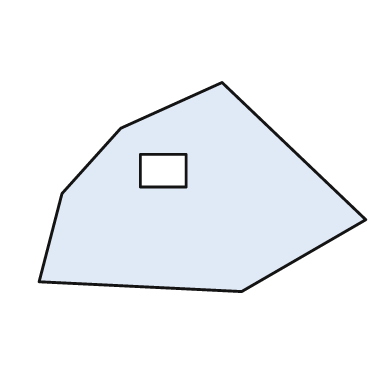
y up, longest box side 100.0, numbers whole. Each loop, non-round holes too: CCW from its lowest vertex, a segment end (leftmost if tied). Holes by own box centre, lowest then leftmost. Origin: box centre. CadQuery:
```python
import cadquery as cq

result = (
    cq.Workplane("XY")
    .moveTo(12.0, -32.0)
    .lineTo(50.0, -10.0)
    .lineTo(6.0, 32.0)
    .lineTo(-25.0, 18.0)
    .lineTo(-43.0, -2.0)
    .lineTo(-50.0, -29.0)
    .close()
    .moveTo(-19.0, 0.0)
    .lineTo(-5.0, 0.0)
    .lineTo(-5.0, 10.0)
    .lineTo(-19.0, 10.0)
    .close()
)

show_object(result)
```